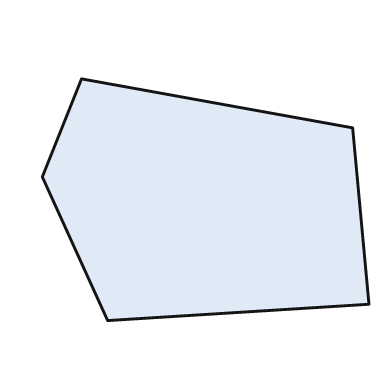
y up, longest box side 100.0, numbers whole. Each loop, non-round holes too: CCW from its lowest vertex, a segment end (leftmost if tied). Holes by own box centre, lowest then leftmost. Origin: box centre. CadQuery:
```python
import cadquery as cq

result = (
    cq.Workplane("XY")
    .moveTo(-30.0, -37.0)
    .lineTo(50.0, -32.0)
    .lineTo(45.0, 22.0)
    .lineTo(-38.0, 37.0)
    .lineTo(-50.0, 7.0)
    .close()
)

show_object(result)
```